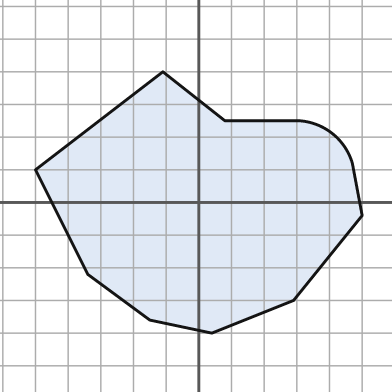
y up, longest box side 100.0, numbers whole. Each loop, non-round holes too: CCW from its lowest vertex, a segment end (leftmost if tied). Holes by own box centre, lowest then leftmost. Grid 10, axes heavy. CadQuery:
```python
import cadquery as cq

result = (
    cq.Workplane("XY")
    .moveTo(4.0, -40.0)
    .lineTo(29.0, -30.0)
    .lineTo(50.0, -4.0)
    .lineTo(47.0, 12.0)
    .threePointArc((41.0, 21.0), (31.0, 25.0))
    .lineTo(8.0, 25.0)
    .lineTo(-11.0, 40.0)
    .lineTo(-50.0, 10.0)
    .lineTo(-34.0, -22.0)
    .lineTo(-15.0, -36.0)
    .close()
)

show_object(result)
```